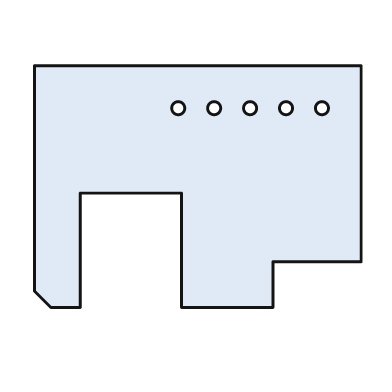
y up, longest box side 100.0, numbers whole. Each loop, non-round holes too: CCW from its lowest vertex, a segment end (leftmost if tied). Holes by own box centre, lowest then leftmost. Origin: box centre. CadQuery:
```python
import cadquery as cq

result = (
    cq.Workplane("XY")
    .moveTo(-45.0, -37.0)
    .lineTo(-36.0, -37.0)
    .lineTo(-36.0, -2.0)
    .lineTo(-5.0, -2.0)
    .lineTo(-5.0, -37.0)
    .lineTo(23.0, -37.0)
    .lineTo(23.0, -23.0)
    .lineTo(50.0, -23.0)
    .lineTo(50.0, 37.0)
    .lineTo(-50.0, 37.0)
    .lineTo(-50.0, -32.0)
    .close()
    .moveTo(-6.0, 24.0)
    .circle(2.0)
    .moveTo(5.0, 24.0)
    .circle(2.0)
    .moveTo(16.0, 24.0)
    .circle(2.0)
    .moveTo(27.0, 24.0)
    .circle(2.0)
    .moveTo(38.0, 24.0)
    .circle(2.0)
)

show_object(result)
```